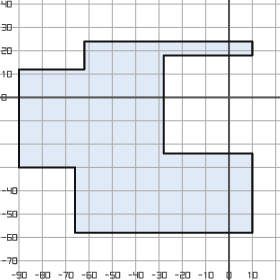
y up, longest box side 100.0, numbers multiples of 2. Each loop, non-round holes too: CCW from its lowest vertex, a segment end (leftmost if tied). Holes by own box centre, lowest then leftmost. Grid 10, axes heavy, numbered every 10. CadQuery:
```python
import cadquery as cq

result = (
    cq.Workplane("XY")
    .moveTo(-66.0, -58.0)
    .lineTo(10.0, -58.0)
    .lineTo(10.0, -24.0)
    .lineTo(-28.0, -24.0)
    .lineTo(-28.0, 18.0)
    .lineTo(10.0, 18.0)
    .lineTo(10.0, 24.0)
    .lineTo(-62.0, 24.0)
    .lineTo(-62.0, 12.0)
    .lineTo(-90.0, 12.0)
    .lineTo(-90.0, -30.0)
    .lineTo(-66.0, -30.0)
    .close()
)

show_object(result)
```